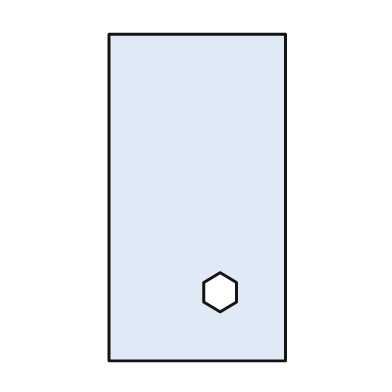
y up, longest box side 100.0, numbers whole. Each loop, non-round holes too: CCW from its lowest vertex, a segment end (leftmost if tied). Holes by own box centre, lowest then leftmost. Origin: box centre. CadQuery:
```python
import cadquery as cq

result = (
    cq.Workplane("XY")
    .moveTo(-27.0, -50.0)
    .lineTo(27.0, -50.0)
    .lineTo(27.0, 50.0)
    .lineTo(-27.0, 50.0)
    .close()
    .moveTo(7.0, -35.0)
    .lineTo(12.0, -32.0)
    .lineTo(12.0, -26.0)
    .lineTo(7.0, -23.0)
    .lineTo(2.0, -26.0)
    .lineTo(2.0, -32.0)
    .close()
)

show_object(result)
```